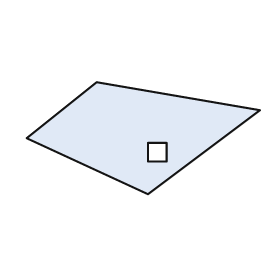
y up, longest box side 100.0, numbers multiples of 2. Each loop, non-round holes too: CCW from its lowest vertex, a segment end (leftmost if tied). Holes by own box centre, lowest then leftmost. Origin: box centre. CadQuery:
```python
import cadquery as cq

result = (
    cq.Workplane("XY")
    .moveTo(2.0, -24.0)
    .lineTo(50.0, 12.0)
    .lineTo(-20.0, 24.0)
    .lineTo(-50.0, 0.0)
    .close()
    .moveTo(2.0, -10.0)
    .lineTo(10.0, -10.0)
    .lineTo(10.0, -2.0)
    .lineTo(2.0, -2.0)
    .close()
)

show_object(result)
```